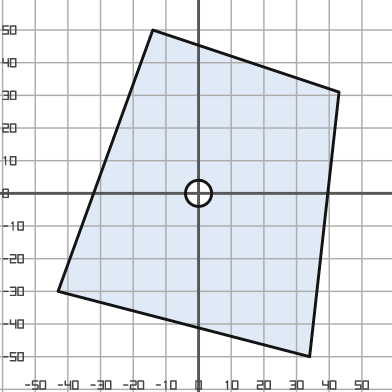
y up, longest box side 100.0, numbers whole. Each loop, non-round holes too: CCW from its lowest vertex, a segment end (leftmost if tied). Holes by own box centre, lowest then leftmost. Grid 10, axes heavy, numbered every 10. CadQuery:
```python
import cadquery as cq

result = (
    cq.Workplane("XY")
    .moveTo(34.0, -50.0)
    .lineTo(43.0, 31.0)
    .lineTo(-14.0, 50.0)
    .lineTo(-43.0, -30.0)
    .close()
    .moveTo(0.0, 0.0)
    .circle(4.0)
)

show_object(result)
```